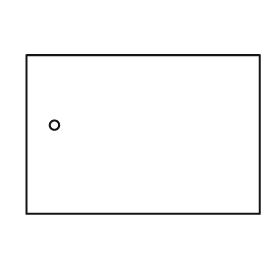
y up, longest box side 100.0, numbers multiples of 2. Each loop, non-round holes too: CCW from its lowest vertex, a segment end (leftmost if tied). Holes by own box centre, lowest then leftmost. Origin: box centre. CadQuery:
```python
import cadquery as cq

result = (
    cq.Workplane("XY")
    .moveTo(-50.0, -34.0)
    .lineTo(50.0, -34.0)
    .lineTo(50.0, 34.0)
    .lineTo(-50.0, 34.0)
    .close()
    .moveTo(-38.0, 4.0)
    .circle(2.0)
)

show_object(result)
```